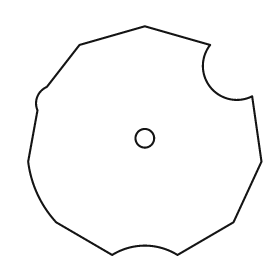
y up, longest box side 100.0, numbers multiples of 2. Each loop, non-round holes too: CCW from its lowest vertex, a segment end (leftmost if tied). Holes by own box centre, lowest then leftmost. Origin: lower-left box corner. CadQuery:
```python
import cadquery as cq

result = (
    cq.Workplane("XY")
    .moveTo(36.0, 0.0)
    .threePointArc((50.0, 4.0), (64.0, 0.0))
    .lineTo(88.0, 14.0)
    .lineTo(100.0, 40.0)
    .lineTo(96.0, 68.0)
    .threePointArc((78.0, 72.0), (78.0, 90.0))
    .lineTo(50.0, 98.0)
    .lineTo(22.0, 90.0)
    .lineTo(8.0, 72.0)
    .threePointArc((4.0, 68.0), (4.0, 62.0))
    .lineTo(0.0, 40.0)
    .threePointArc((4.0, 26.0), (12.0, 14.0))
    .close()
    .moveTo(50.0, 50.0)
    .circle(4.0)
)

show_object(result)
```